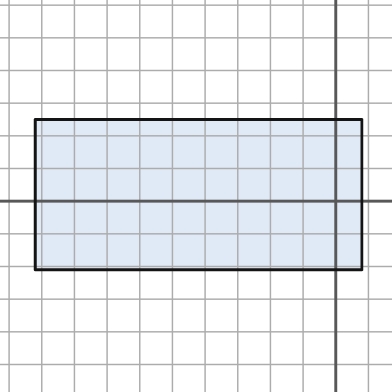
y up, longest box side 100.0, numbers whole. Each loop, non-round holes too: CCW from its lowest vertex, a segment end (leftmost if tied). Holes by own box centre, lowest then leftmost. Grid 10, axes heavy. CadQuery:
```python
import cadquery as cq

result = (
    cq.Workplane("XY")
    .moveTo(-92.0, -21.0)
    .lineTo(8.0, -21.0)
    .lineTo(8.0, 25.0)
    .lineTo(-92.0, 25.0)
    .close()
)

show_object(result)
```